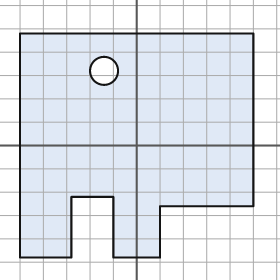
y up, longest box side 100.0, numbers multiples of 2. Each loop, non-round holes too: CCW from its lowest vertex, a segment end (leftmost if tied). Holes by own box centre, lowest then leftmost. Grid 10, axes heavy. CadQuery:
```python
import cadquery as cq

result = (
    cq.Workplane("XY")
    .moveTo(-50.0, -48.0)
    .lineTo(-28.0, -48.0)
    .lineTo(-28.0, -22.0)
    .lineTo(-10.0, -22.0)
    .lineTo(-10.0, -48.0)
    .lineTo(10.0, -48.0)
    .lineTo(10.0, -26.0)
    .lineTo(50.0, -26.0)
    .lineTo(50.0, 48.0)
    .lineTo(-50.0, 48.0)
    .close()
    .moveTo(-14.0, 32.0)
    .circle(6.0)
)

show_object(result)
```